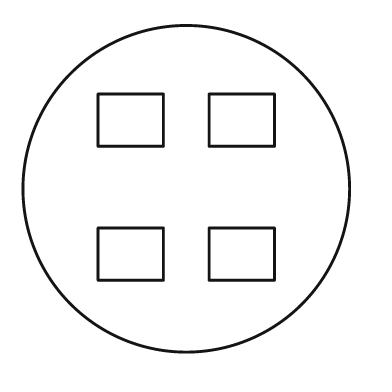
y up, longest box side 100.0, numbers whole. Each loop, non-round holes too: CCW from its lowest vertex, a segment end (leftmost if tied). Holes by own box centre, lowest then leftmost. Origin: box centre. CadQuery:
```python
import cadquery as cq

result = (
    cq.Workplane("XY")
    .moveTo(0.0, 0.0)
    .circle(50.0)
    .moveTo(-27.0, -28.0)
    .lineTo(-7.0, -28.0)
    .lineTo(-7.0, -12.0)
    .lineTo(-27.0, -12.0)
    .close()
    .moveTo(7.0, -28.0)
    .lineTo(27.0, -28.0)
    .lineTo(27.0, -12.0)
    .lineTo(7.0, -12.0)
    .close()
    .moveTo(-27.0, 13.0)
    .lineTo(-7.0, 13.0)
    .lineTo(-7.0, 29.0)
    .lineTo(-27.0, 29.0)
    .close()
    .moveTo(7.0, 13.0)
    .lineTo(27.0, 13.0)
    .lineTo(27.0, 29.0)
    .lineTo(7.0, 29.0)
    .close()
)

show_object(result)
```